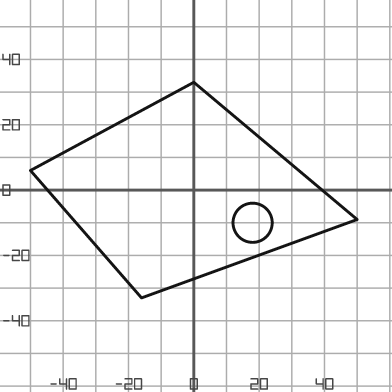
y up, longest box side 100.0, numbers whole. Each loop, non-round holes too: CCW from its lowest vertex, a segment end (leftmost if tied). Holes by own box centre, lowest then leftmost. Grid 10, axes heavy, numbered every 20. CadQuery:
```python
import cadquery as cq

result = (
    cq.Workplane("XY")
    .moveTo(-16.0, -33.0)
    .lineTo(50.0, -9.0)
    .lineTo(0.0, 33.0)
    .lineTo(-50.0, 6.0)
    .close()
    .moveTo(18.0, -10.0)
    .circle(6.0)
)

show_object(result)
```